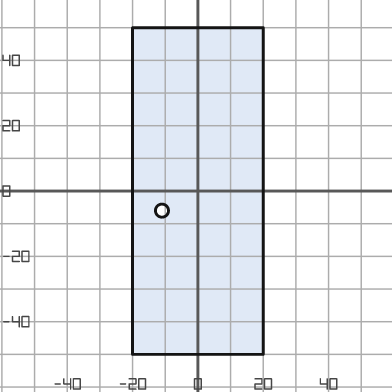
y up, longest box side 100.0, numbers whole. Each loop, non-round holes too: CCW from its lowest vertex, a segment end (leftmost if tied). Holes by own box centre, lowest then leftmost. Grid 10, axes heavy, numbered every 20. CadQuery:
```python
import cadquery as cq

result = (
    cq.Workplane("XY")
    .moveTo(-20.0, -50.0)
    .lineTo(20.0, -50.0)
    .lineTo(20.0, 50.0)
    .lineTo(-20.0, 50.0)
    .close()
    .moveTo(-11.0, -6.0)
    .circle(2.0)
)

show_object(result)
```